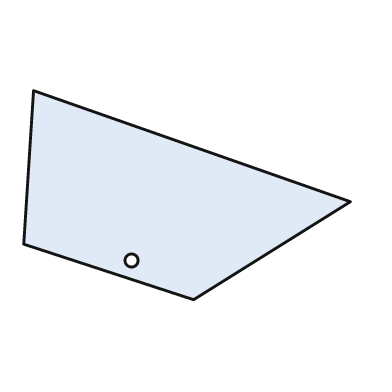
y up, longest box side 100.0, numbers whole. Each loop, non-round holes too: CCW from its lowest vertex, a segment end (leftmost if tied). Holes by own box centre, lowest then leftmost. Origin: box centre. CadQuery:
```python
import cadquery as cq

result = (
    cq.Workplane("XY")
    .moveTo(2.0, -32.0)
    .lineTo(50.0, -2.0)
    .lineTo(-47.0, 32.0)
    .lineTo(-50.0, -15.0)
    .close()
    .moveTo(-17.0, -20.0)
    .circle(2.0)
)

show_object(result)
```